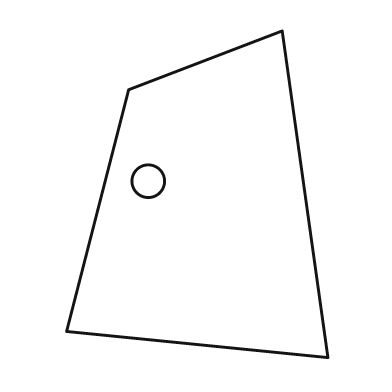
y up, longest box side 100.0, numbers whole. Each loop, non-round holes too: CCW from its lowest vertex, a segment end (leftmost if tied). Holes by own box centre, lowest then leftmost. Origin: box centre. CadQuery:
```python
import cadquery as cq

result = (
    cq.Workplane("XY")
    .moveTo(40.0, -50.0)
    .lineTo(26.0, 50.0)
    .lineTo(-21.0, 32.0)
    .lineTo(-40.0, -42.0)
    .close()
    .moveTo(-15.0, 4.0)
    .circle(5.0)
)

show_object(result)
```